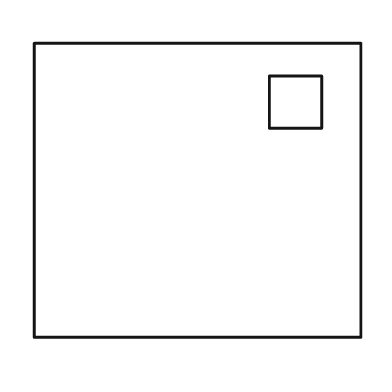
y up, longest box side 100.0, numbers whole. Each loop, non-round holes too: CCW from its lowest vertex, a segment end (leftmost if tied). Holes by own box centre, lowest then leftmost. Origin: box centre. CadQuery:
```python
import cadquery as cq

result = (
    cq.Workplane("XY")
    .moveTo(-50.0, -45.0)
    .lineTo(50.0, -45.0)
    .lineTo(50.0, 45.0)
    .lineTo(-50.0, 45.0)
    .close()
    .moveTo(22.0, 19.0)
    .lineTo(38.0, 19.0)
    .lineTo(38.0, 35.0)
    .lineTo(22.0, 35.0)
    .close()
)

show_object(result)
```